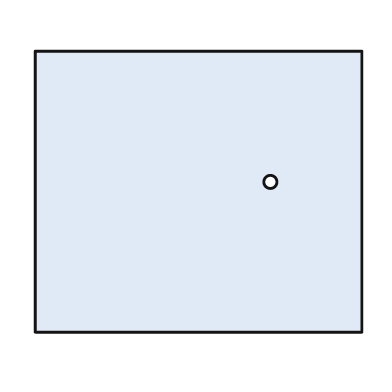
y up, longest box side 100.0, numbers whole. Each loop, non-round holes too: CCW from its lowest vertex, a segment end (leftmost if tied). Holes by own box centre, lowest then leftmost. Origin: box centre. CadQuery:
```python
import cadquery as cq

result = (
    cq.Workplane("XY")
    .moveTo(-50.0, -43.0)
    .lineTo(50.0, -43.0)
    .lineTo(50.0, 43.0)
    .lineTo(-50.0, 43.0)
    .close()
    .moveTo(22.0, 3.0)
    .circle(2.0)
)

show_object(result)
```